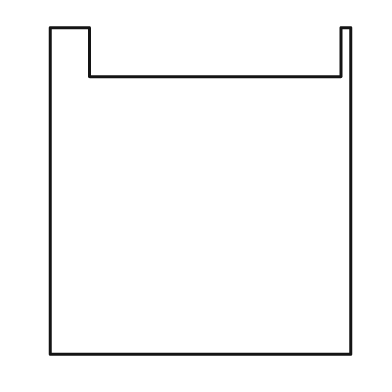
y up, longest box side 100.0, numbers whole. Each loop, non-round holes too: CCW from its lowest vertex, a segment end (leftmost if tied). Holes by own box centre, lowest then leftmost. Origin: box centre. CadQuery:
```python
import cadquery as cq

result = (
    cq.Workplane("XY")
    .moveTo(-46.0, -50.0)
    .lineTo(46.0, -50.0)
    .lineTo(46.0, 50.0)
    .lineTo(43.0, 50.0)
    .lineTo(43.0, 35.0)
    .lineTo(-34.0, 35.0)
    .lineTo(-34.0, 50.0)
    .lineTo(-46.0, 50.0)
    .close()
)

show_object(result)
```